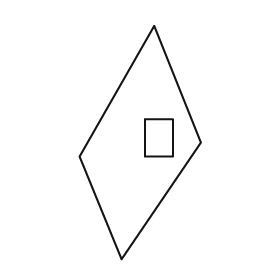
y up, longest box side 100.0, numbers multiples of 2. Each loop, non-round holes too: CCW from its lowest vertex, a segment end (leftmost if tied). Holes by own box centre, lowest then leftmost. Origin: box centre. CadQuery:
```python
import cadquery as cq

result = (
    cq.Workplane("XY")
    .moveTo(-8.0, -50.0)
    .lineTo(26.0, 0.0)
    .lineTo(6.0, 50.0)
    .lineTo(-26.0, -6.0)
    .close()
    .moveTo(2.0, -6.0)
    .lineTo(14.0, -6.0)
    .lineTo(14.0, 10.0)
    .lineTo(2.0, 10.0)
    .close()
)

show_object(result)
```